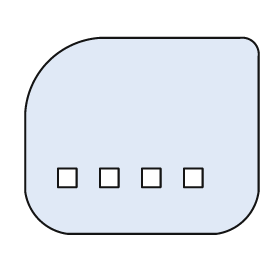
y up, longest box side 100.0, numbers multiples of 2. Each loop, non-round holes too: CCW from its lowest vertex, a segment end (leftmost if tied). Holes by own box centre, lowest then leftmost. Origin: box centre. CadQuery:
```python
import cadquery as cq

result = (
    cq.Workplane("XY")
    .moveTo(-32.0, -42.0)
    .lineTo(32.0, -42.0)
    .threePointArc((44.0, -36.0), (50.0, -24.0))
    .lineTo(50.0, 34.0)
    .threePointArc((48.0, 40.0), (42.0, 42.0))
    .lineTo(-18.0, 42.0)
    .threePointArc((-40.0, 32.0), (-50.0, 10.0))
    .lineTo(-50.0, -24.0)
    .threePointArc((-44.0, -36.0), (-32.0, -42.0))
    .close()
    .moveTo(-36.0, -22.0)
    .lineTo(-28.0, -22.0)
    .lineTo(-28.0, -14.0)
    .lineTo(-36.0, -14.0)
    .close()
    .moveTo(-18.0, -22.0)
    .lineTo(-10.0, -22.0)
    .lineTo(-10.0, -14.0)
    .lineTo(-18.0, -14.0)
    .close()
    .moveTo(0.0, -22.0)
    .lineTo(8.0, -22.0)
    .lineTo(8.0, -14.0)
    .lineTo(0.0, -14.0)
    .close()
    .moveTo(18.0, -22.0)
    .lineTo(26.0, -22.0)
    .lineTo(26.0, -14.0)
    .lineTo(18.0, -14.0)
    .close()
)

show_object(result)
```